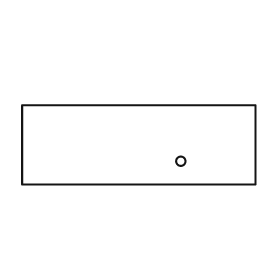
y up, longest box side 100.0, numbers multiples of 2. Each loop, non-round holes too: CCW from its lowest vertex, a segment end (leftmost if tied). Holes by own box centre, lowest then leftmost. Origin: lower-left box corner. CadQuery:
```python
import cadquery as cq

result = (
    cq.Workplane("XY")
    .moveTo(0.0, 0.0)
    .lineTo(100.0, 0.0)
    .lineTo(100.0, 34.0)
    .lineTo(0.0, 34.0)
    .close()
    .moveTo(68.0, 10.0)
    .circle(2.0)
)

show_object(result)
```